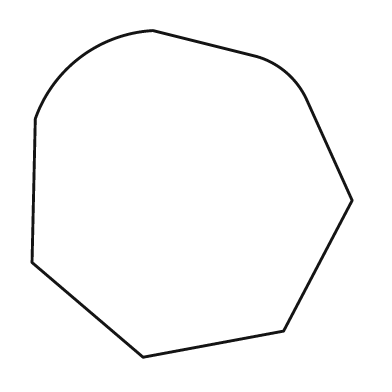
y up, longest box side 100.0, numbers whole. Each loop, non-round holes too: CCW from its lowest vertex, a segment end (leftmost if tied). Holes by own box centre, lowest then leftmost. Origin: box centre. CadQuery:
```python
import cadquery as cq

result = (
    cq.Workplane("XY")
    .moveTo(-15.0, -50.0)
    .lineTo(28.0, -42.0)
    .lineTo(49.0, -2.0)
    .lineTo(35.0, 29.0)
    .threePointArc((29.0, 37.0), (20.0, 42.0))
    .lineTo(-12.0, 50.0)
    .threePointArc((-34.0, 42.0), (-48.0, 23.0))
    .lineTo(-49.0, -21.0)
    .close()
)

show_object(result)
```